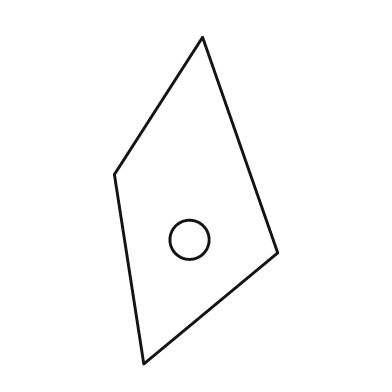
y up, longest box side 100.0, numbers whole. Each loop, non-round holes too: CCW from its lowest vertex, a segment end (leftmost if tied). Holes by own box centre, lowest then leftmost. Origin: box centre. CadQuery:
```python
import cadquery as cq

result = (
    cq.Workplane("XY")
    .moveTo(-16.0, -50.0)
    .lineTo(25.0, -16.0)
    .lineTo(2.0, 50.0)
    .lineTo(-25.0, 8.0)
    .close()
    .moveTo(-2.0, -12.0)
    .circle(6.0)
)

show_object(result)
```